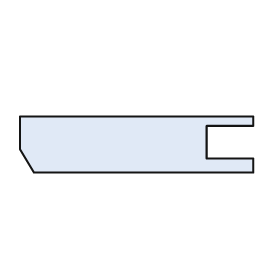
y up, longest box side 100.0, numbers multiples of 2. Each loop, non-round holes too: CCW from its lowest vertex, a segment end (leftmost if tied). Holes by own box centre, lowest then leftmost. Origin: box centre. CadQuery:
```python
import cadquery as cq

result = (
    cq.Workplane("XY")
    .moveTo(-44.0, -12.0)
    .lineTo(50.0, -12.0)
    .lineTo(50.0, -6.0)
    .lineTo(30.0, -6.0)
    .lineTo(30.0, 8.0)
    .lineTo(50.0, 8.0)
    .lineTo(50.0, 12.0)
    .lineTo(-50.0, 12.0)
    .lineTo(-50.0, -2.0)
    .close()
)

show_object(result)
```